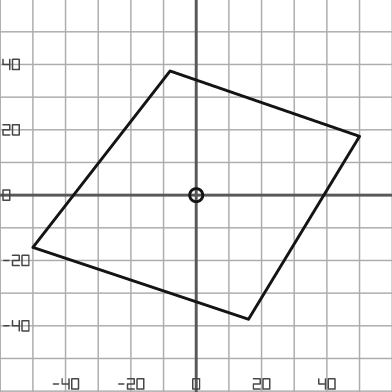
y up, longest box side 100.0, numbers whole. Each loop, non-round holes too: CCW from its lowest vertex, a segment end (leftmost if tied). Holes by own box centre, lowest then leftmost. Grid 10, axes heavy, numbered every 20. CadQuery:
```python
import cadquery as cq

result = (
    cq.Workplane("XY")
    .moveTo(16.0, -38.0)
    .lineTo(50.0, 18.0)
    .lineTo(-8.0, 38.0)
    .lineTo(-50.0, -16.0)
    .close()
    .moveTo(0.0, 0.0)
    .circle(2.0)
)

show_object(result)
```